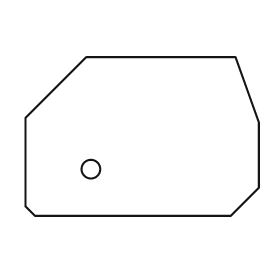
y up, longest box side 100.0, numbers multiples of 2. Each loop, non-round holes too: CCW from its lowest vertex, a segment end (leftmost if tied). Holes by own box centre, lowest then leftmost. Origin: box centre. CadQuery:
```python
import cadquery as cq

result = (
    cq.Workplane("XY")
    .moveTo(-46.0, -34.0)
    .lineTo(38.0, -34.0)
    .lineTo(50.0, -22.0)
    .lineTo(50.0, 6.0)
    .lineTo(40.0, 34.0)
    .lineTo(-24.0, 34.0)
    .lineTo(-50.0, 8.0)
    .lineTo(-50.0, -30.0)
    .close()
    .moveTo(-22.0, -14.0)
    .circle(4.0)
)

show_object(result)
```